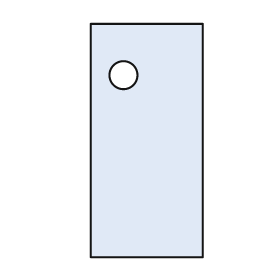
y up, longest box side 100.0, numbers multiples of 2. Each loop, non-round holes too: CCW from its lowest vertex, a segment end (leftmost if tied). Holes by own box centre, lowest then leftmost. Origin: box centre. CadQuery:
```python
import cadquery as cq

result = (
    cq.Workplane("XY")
    .moveTo(-24.0, -50.0)
    .lineTo(24.0, -50.0)
    .lineTo(24.0, 50.0)
    .lineTo(-24.0, 50.0)
    .close()
    .moveTo(-10.0, 28.0)
    .circle(6.0)
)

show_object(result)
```